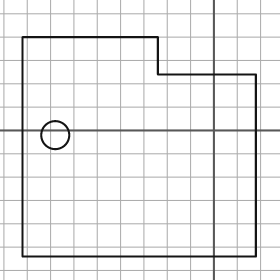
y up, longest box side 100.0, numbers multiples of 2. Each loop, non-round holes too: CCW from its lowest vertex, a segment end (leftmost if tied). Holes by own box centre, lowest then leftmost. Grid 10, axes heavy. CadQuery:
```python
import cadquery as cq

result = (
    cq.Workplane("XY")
    .moveTo(-82.0, -54.0)
    .lineTo(18.0, -54.0)
    .lineTo(18.0, 24.0)
    .lineTo(-24.0, 24.0)
    .lineTo(-24.0, 40.0)
    .lineTo(-82.0, 40.0)
    .close()
    .moveTo(-68.0, -2.0)
    .circle(6.0)
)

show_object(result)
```